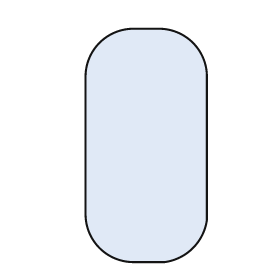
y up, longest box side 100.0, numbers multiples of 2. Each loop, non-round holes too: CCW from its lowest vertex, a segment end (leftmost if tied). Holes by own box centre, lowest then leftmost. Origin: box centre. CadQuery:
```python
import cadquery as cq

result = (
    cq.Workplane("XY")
    .moveTo(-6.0, -50.0)
    .lineTo(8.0, -50.0)
    .threePointArc((20.0, -44.0), (26.0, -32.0))
    .lineTo(26.0, 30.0)
    .threePointArc((20.0, 44.0), (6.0, 50.0))
    .lineTo(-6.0, 50.0)
    .threePointArc((-20.0, 44.0), (-26.0, 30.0))
    .lineTo(-26.0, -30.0)
    .threePointArc((-20.0, -44.0), (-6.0, -50.0))
    .close()
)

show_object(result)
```